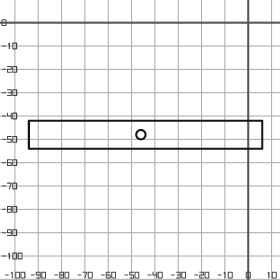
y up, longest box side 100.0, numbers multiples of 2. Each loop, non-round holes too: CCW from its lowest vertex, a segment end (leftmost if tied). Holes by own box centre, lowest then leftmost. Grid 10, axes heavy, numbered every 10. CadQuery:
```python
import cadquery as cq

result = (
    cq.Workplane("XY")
    .moveTo(-94.0, -54.0)
    .lineTo(6.0, -54.0)
    .lineTo(6.0, -42.0)
    .lineTo(-94.0, -42.0)
    .close()
    .moveTo(-46.0, -48.0)
    .circle(2.0)
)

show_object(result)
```